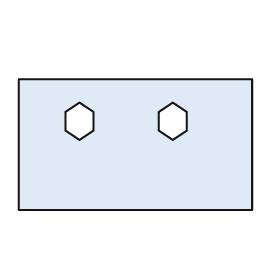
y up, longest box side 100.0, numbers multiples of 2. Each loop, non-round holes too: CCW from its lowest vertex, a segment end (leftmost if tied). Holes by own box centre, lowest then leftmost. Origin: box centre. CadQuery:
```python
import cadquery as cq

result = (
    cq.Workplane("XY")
    .moveTo(-50.0, -28.0)
    .lineTo(50.0, -28.0)
    .lineTo(50.0, 28.0)
    .lineTo(-50.0, 28.0)
    .close()
    .moveTo(-24.0, 2.0)
    .lineTo(-18.0, 6.0)
    .lineTo(-18.0, 14.0)
    .lineTo(-24.0, 18.0)
    .lineTo(-30.0, 14.0)
    .lineTo(-30.0, 6.0)
    .close()
    .moveTo(16.0, 2.0)
    .lineTo(22.0, 6.0)
    .lineTo(22.0, 14.0)
    .lineTo(16.0, 18.0)
    .lineTo(10.0, 14.0)
    .lineTo(10.0, 6.0)
    .close()
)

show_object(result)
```